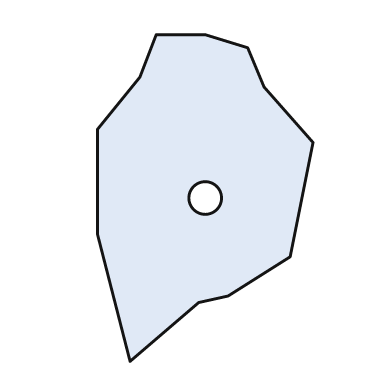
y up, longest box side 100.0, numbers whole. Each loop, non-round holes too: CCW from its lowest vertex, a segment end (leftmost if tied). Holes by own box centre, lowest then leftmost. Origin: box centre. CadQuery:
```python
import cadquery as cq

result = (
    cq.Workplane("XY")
    .moveTo(-23.0, -50.0)
    .lineTo(-2.0, -32.0)
    .lineTo(7.0, -30.0)
    .lineTo(26.0, -18.0)
    .lineTo(33.0, 17.0)
    .lineTo(18.0, 34.0)
    .lineTo(13.0, 46.0)
    .lineTo(0.0, 50.0)
    .lineTo(-15.0, 50.0)
    .lineTo(-20.0, 37.0)
    .lineTo(-33.0, 21.0)
    .lineTo(-33.0, -11.0)
    .close()
    .moveTo(0.0, 0.0)
    .circle(5.0)
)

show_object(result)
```